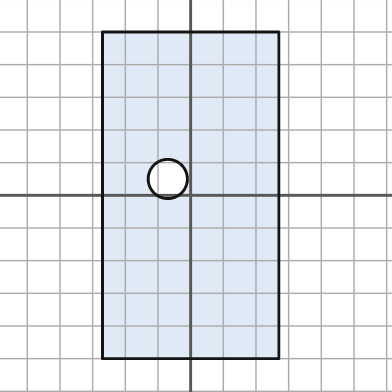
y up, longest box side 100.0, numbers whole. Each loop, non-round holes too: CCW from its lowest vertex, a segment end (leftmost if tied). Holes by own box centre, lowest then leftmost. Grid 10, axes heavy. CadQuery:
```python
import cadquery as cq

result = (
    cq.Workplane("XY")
    .moveTo(-27.0, -50.0)
    .lineTo(27.0, -50.0)
    .lineTo(27.0, 50.0)
    .lineTo(-27.0, 50.0)
    .close()
    .moveTo(-7.0, 5.0)
    .circle(6.0)
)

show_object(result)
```